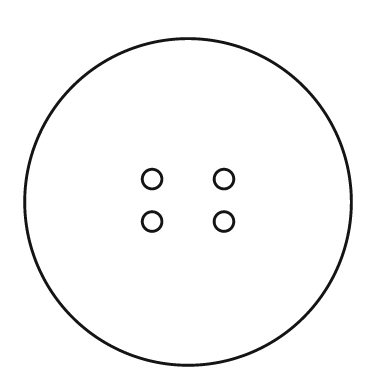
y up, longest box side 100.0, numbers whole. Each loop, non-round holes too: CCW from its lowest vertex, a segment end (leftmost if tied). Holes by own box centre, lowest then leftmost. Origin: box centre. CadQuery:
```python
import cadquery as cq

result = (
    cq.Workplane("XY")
    .moveTo(0.0, 0.0)
    .circle(50.0)
    .moveTo(-11.0, -6.0)
    .circle(3.0)
    .moveTo(11.0, -6.0)
    .circle(3.0)
    .moveTo(-11.0, 7.0)
    .circle(3.0)
    .moveTo(11.0, 7.0)
    .circle(3.0)
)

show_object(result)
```